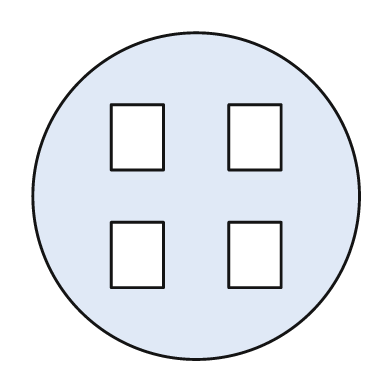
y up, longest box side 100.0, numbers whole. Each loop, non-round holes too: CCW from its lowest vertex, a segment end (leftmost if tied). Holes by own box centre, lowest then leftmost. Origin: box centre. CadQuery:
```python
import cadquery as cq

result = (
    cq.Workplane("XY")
    .moveTo(0.0, 0.0)
    .circle(50.0)
    .moveTo(-26.0, -28.0)
    .lineTo(-10.0, -28.0)
    .lineTo(-10.0, -8.0)
    .lineTo(-26.0, -8.0)
    .close()
    .moveTo(10.0, -28.0)
    .lineTo(26.0, -28.0)
    .lineTo(26.0, -8.0)
    .lineTo(10.0, -8.0)
    .close()
    .moveTo(-26.0, 8.0)
    .lineTo(-10.0, 8.0)
    .lineTo(-10.0, 28.0)
    .lineTo(-26.0, 28.0)
    .close()
    .moveTo(10.0, 8.0)
    .lineTo(26.0, 8.0)
    .lineTo(26.0, 28.0)
    .lineTo(10.0, 28.0)
    .close()
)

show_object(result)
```